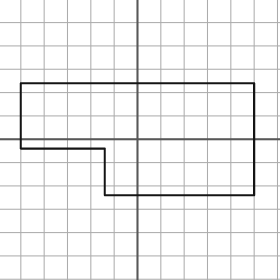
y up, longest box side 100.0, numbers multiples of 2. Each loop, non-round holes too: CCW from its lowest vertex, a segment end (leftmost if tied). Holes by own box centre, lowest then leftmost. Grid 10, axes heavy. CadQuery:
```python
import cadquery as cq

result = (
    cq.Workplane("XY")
    .moveTo(-14.0, -24.0)
    .lineTo(50.0, -24.0)
    .lineTo(50.0, 24.0)
    .lineTo(-50.0, 24.0)
    .lineTo(-50.0, -4.0)
    .lineTo(-14.0, -4.0)
    .close()
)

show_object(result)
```